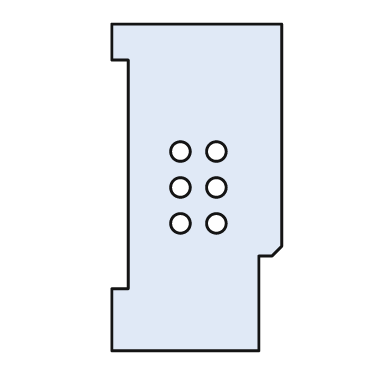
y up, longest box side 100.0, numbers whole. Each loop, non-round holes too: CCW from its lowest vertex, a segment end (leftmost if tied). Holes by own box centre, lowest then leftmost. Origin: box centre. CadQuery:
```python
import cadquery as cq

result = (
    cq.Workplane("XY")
    .moveTo(-26.0, -50.0)
    .lineTo(19.0, -50.0)
    .lineTo(19.0, -21.0)
    .lineTo(23.0, -21.0)
    .lineTo(26.0, -18.0)
    .lineTo(26.0, 50.0)
    .lineTo(-26.0, 50.0)
    .lineTo(-26.0, 39.0)
    .lineTo(-21.0, 39.0)
    .lineTo(-21.0, -31.0)
    .lineTo(-26.0, -31.0)
    .close()
    .moveTo(-5.0, -11.0)
    .circle(3.0)
    .moveTo(6.0, -11.0)
    .circle(3.0)
    .moveTo(-5.0, 0.0)
    .circle(3.0)
    .moveTo(6.0, 0.0)
    .circle(3.0)
    .moveTo(-5.0, 11.0)
    .circle(3.0)
    .moveTo(6.0, 11.0)
    .circle(3.0)
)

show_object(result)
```